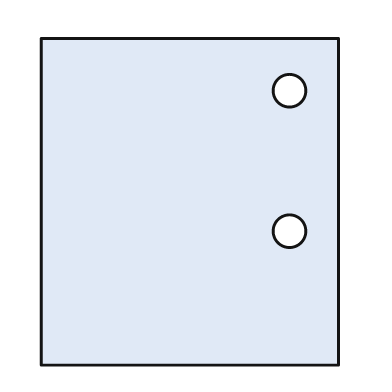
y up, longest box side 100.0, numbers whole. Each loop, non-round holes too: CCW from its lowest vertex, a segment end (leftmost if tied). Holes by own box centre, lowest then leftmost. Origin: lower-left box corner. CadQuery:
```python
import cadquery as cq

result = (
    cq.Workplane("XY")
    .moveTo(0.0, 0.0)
    .lineTo(91.0, 0.0)
    .lineTo(91.0, 100.0)
    .lineTo(0.0, 100.0)
    .close()
    .moveTo(76.0, 41.0)
    .circle(5.0)
    .moveTo(76.0, 84.0)
    .circle(5.0)
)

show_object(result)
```